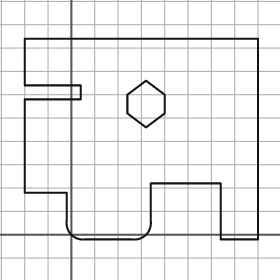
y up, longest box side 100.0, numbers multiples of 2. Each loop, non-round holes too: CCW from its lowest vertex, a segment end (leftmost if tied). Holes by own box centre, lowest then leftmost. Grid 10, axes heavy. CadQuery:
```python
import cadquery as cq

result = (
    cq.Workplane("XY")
    .moveTo(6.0, -2.0)
    .lineTo(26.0, -2.0)
    .threePointArc((32.0, 0.0), (34.0, 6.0))
    .lineTo(34.0, 22.0)
    .lineTo(64.0, 22.0)
    .lineTo(64.0, -2.0)
    .lineTo(80.0, -2.0)
    .lineTo(80.0, 84.0)
    .lineTo(-20.0, 84.0)
    .lineTo(-20.0, 64.0)
    .lineTo(4.0, 64.0)
    .lineTo(4.0, 58.0)
    .lineTo(-20.0, 58.0)
    .lineTo(-20.0, 18.0)
    .lineTo(-2.0, 18.0)
    .lineTo(-2.0, 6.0)
    .threePointArc((0.0, 0.0), (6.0, -2.0))
    .close()
    .moveTo(32.0, 46.0)
    .lineTo(40.0, 52.0)
    .lineTo(40.0, 60.0)
    .lineTo(32.0, 66.0)
    .lineTo(24.0, 60.0)
    .lineTo(24.0, 52.0)
    .close()
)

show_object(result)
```